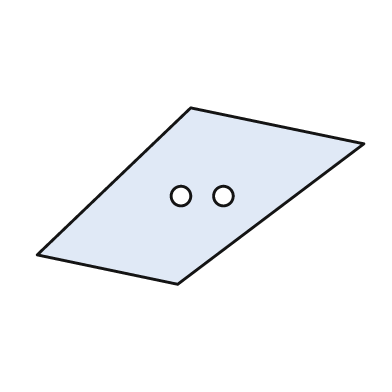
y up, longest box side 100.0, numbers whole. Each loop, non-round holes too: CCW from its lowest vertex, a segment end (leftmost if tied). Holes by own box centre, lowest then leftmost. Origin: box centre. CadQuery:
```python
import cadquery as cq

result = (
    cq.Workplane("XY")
    .moveTo(-7.0, -27.0)
    .lineTo(50.0, 16.0)
    .lineTo(-3.0, 27.0)
    .lineTo(-50.0, -18.0)
    .close()
    .moveTo(-6.0, 0.0)
    .circle(3.0)
    .moveTo(7.0, 0.0)
    .circle(3.0)
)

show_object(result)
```